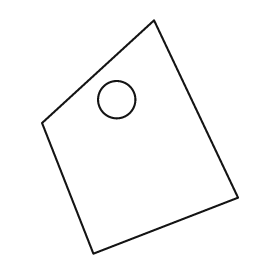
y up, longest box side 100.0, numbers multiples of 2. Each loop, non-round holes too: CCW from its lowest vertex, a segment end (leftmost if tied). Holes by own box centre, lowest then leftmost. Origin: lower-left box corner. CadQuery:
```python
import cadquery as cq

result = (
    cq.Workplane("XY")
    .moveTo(22.0, 0.0)
    .lineTo(84.0, 24.0)
    .lineTo(48.0, 100.0)
    .lineTo(0.0, 56.0)
    .close()
    .moveTo(32.0, 66.0)
    .circle(8.0)
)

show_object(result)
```